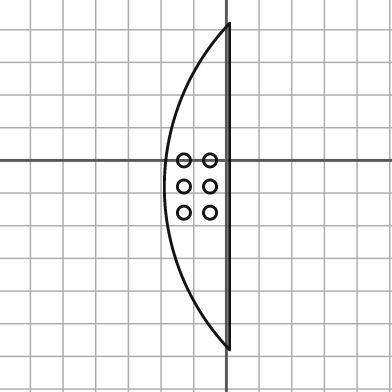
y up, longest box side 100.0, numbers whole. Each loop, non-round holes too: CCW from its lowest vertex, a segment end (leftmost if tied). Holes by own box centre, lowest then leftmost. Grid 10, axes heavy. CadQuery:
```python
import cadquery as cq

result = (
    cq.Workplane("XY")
    .moveTo(1.0, -58.0)
    .lineTo(1.0, 42.0)
    .threePointArc((-19.0, -8.0), (1.0, -58.0))
    .close()
    .moveTo(-13.0, -16.0)
    .circle(2.0)
    .moveTo(-5.0, -16.0)
    .circle(2.0)
    .moveTo(-13.0, -8.0)
    .circle(2.0)
    .moveTo(-5.0, -8.0)
    .circle(2.0)
    .moveTo(-13.0, 0.0)
    .circle(2.0)
    .moveTo(-5.0, 0.0)
    .circle(2.0)
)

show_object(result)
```